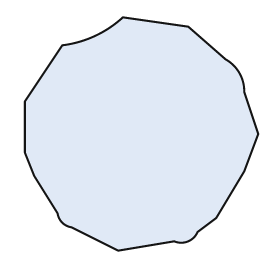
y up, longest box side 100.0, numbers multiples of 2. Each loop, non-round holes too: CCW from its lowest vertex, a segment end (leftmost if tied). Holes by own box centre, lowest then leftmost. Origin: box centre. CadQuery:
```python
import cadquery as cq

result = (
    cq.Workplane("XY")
    .moveTo(-10.0, -50.0)
    .lineTo(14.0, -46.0)
    .threePointArc((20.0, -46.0), (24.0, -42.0))
    .lineTo(32.0, -36.0)
    .lineTo(44.0, -16.0)
    .lineTo(50.0, 0.0)
    .lineTo(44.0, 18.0)
    .threePointArc((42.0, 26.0), (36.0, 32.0))
    .lineTo(20.0, 46.0)
    .lineTo(-8.0, 50.0)
    .threePointArc((-20.0, 42.0), (-34.0, 38.0))
    .lineTo(-50.0, 14.0)
    .lineTo(-50.0, -8.0)
    .lineTo(-46.0, -18.0)
    .lineTo(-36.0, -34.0)
    .threePointArc((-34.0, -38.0), (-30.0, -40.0))
    .close()
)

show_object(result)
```